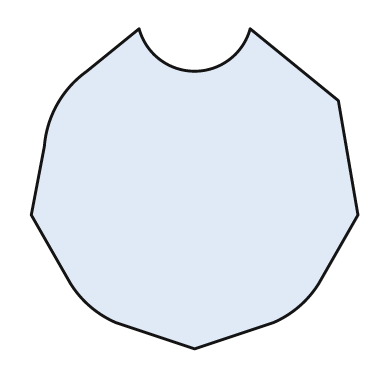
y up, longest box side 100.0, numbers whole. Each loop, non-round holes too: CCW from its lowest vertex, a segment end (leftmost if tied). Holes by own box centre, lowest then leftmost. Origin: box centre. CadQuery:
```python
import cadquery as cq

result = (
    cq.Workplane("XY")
    .moveTo(0.0, -49.0)
    .lineTo(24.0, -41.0)
    .threePointArc((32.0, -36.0), (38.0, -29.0))
    .lineTo(50.0, -8.0)
    .lineTo(44.0, 27.0)
    .lineTo(17.0, 49.0)
    .threePointArc((0.0, 36.0), (-17.0, 49.0))
    .lineTo(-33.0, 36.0)
    .threePointArc((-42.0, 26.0), (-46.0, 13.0))
    .lineTo(-50.0, -8.0)
    .lineTo(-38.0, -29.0)
    .threePointArc((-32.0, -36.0), (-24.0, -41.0))
    .close()
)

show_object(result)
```